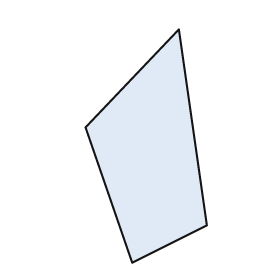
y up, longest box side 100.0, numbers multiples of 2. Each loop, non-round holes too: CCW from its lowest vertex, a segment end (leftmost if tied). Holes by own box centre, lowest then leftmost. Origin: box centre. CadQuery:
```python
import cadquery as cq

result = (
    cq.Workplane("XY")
    .moveTo(-6.0, -50.0)
    .lineTo(26.0, -34.0)
    .lineTo(14.0, 50.0)
    .lineTo(-26.0, 8.0)
    .close()
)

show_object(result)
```